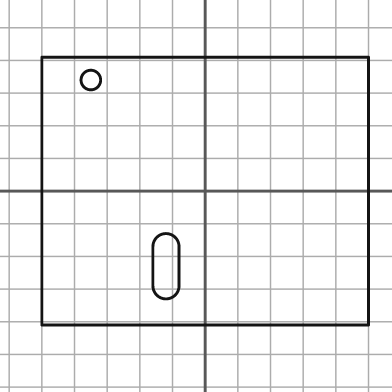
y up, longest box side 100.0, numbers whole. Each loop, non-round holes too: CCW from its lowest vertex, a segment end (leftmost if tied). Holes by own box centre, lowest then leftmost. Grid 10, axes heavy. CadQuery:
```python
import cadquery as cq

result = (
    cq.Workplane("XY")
    .moveTo(-50.0, -41.0)
    .lineTo(50.0, -41.0)
    .lineTo(50.0, 41.0)
    .lineTo(-50.0, 41.0)
    .close()
    .moveTo(-16.0, -29.0)
    .threePointArc((-12.0, -33.0), (-8.0, -29.0))
    .lineTo(-8.0, -17.0)
    .threePointArc((-12.0, -13.0), (-16.0, -17.0))
    .close()
    .moveTo(-35.0, 34.0)
    .circle(3.0)
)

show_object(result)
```